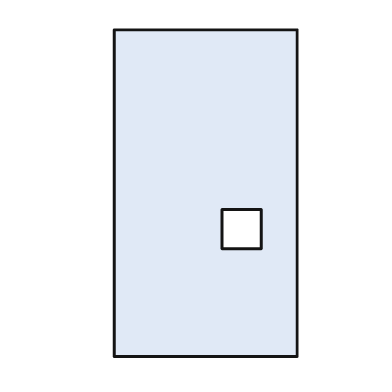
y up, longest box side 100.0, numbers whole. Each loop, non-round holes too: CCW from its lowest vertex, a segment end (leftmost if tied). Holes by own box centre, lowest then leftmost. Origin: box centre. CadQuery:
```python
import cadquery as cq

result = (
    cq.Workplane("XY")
    .moveTo(-28.0, -50.0)
    .lineTo(28.0, -50.0)
    .lineTo(28.0, 50.0)
    .lineTo(-28.0, 50.0)
    .close()
    .moveTo(5.0, -17.0)
    .lineTo(17.0, -17.0)
    .lineTo(17.0, -5.0)
    .lineTo(5.0, -5.0)
    .close()
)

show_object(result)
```